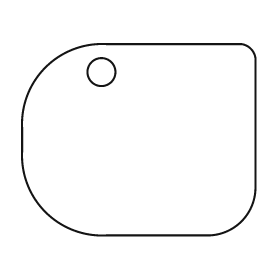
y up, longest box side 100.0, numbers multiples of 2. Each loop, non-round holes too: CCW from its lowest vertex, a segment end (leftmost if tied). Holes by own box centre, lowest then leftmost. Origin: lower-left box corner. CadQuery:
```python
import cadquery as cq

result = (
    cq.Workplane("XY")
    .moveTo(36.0, 0.0)
    .lineTo(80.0, 0.0)
    .threePointArc((94.0, 6.0), (100.0, 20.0))
    .lineTo(100.0, 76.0)
    .threePointArc((98.0, 80.0), (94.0, 82.0))
    .lineTo(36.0, 82.0)
    .threePointArc((10.0, 72.0), (0.0, 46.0))
    .lineTo(0.0, 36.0)
    .threePointArc((10.0, 10.0), (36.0, 0.0))
    .close()
    .moveTo(34.0, 70.0)
    .circle(6.0)
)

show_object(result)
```